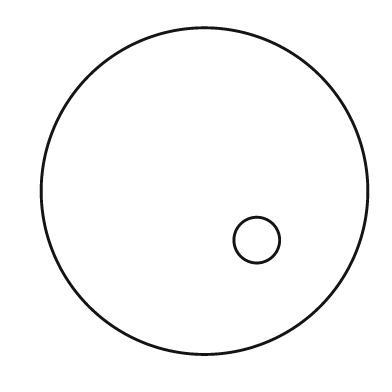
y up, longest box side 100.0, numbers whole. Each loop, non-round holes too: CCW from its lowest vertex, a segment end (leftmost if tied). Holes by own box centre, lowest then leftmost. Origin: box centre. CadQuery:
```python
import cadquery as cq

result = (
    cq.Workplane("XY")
    .moveTo(0.0, 0.0)
    .circle(50.0)
    .moveTo(16.0, -15.0)
    .circle(7.0)
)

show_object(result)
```